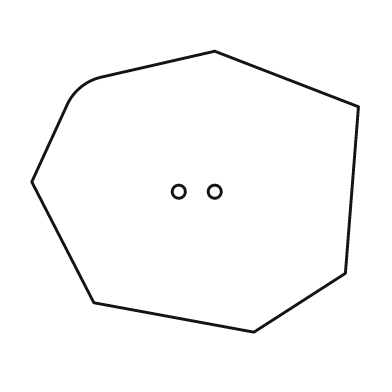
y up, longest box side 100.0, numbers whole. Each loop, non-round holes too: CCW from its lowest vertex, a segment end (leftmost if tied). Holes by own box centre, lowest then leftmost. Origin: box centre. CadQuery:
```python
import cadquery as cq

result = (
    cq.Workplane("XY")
    .moveTo(18.0, -43.0)
    .lineTo(46.0, -25.0)
    .lineTo(50.0, 26.0)
    .lineTo(6.0, 43.0)
    .lineTo(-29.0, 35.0)
    .threePointArc((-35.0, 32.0), (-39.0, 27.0))
    .lineTo(-50.0, 3.0)
    .lineTo(-31.0, -34.0)
    .close()
    .moveTo(-5.0, 0.0)
    .circle(2.0)
    .moveTo(6.0, 0.0)
    .circle(2.0)
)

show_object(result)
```